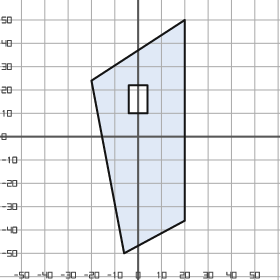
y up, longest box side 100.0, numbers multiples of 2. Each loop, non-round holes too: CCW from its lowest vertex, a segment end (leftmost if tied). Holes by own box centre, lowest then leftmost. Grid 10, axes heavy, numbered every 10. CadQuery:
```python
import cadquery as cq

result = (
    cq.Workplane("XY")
    .moveTo(-6.0, -50.0)
    .lineTo(20.0, -36.0)
    .lineTo(20.0, 50.0)
    .lineTo(-20.0, 24.0)
    .close()
    .moveTo(-4.0, 10.0)
    .lineTo(4.0, 10.0)
    .lineTo(4.0, 22.0)
    .lineTo(-4.0, 22.0)
    .close()
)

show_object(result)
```